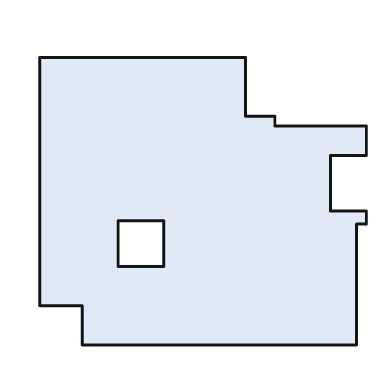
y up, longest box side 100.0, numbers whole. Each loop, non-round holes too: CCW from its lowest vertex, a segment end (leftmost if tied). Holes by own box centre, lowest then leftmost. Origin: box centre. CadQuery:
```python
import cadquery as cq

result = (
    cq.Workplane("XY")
    .moveTo(-37.0, -44.0)
    .lineTo(47.0, -44.0)
    .lineTo(47.0, -7.0)
    .lineTo(50.0, -7.0)
    .lineTo(50.0, -3.0)
    .lineTo(39.0, -3.0)
    .lineTo(39.0, 14.0)
    .lineTo(50.0, 14.0)
    .lineTo(50.0, 23.0)
    .lineTo(22.0, 23.0)
    .lineTo(22.0, 26.0)
    .lineTo(13.0, 26.0)
    .lineTo(13.0, 44.0)
    .lineTo(-50.0, 44.0)
    .lineTo(-50.0, -32.0)
    .lineTo(-37.0, -32.0)
    .close()
    .moveTo(-26.0, -20.0)
    .lineTo(-12.0, -20.0)
    .lineTo(-12.0, -6.0)
    .lineTo(-26.0, -6.0)
    .close()
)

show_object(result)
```